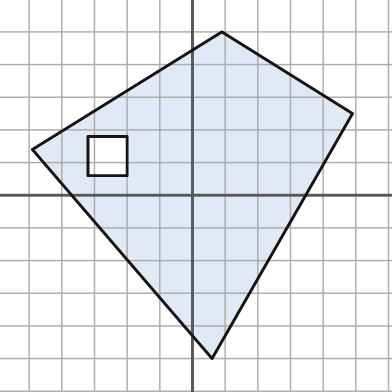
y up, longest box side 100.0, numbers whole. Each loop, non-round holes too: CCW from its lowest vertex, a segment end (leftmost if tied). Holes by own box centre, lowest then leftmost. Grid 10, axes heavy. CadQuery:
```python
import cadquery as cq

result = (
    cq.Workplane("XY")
    .moveTo(6.0, -50.0)
    .lineTo(49.0, 25.0)
    .lineTo(9.0, 50.0)
    .lineTo(-49.0, 14.0)
    .close()
    .moveTo(-32.0, 6.0)
    .lineTo(-20.0, 6.0)
    .lineTo(-20.0, 18.0)
    .lineTo(-32.0, 18.0)
    .close()
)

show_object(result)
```